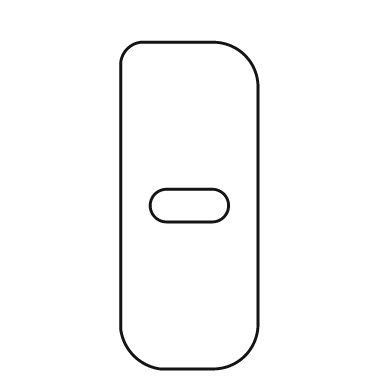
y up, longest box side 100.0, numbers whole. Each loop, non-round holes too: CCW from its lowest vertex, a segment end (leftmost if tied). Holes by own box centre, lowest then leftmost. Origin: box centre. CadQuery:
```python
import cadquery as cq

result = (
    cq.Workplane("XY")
    .moveTo(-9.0, -50.0)
    .lineTo(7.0, -50.0)
    .threePointArc((17.0, -46.0), (21.0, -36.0))
    .lineTo(21.0, 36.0)
    .threePointArc((17.0, 46.0), (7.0, 50.0))
    .lineTo(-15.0, 50.0)
    .threePointArc((-19.0, 48.0), (-21.0, 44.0))
    .lineTo(-21.0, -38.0)
    .threePointArc((-17.0, -46.0), (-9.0, -50.0))
    .close()
    .moveTo(-7.0, -5.0)
    .lineTo(7.0, -5.0)
    .threePointArc((12.0, 0.0), (7.0, 5.0))
    .lineTo(-7.0, 5.0)
    .threePointArc((-12.0, 0.0), (-7.0, -5.0))
    .close()
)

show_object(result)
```